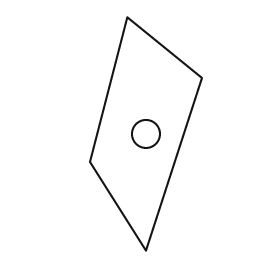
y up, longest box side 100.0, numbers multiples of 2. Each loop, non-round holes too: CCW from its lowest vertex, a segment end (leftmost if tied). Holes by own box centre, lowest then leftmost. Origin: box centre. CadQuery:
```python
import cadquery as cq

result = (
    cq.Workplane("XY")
    .moveTo(0.0, -50.0)
    .lineTo(24.0, 24.0)
    .lineTo(-8.0, 50.0)
    .lineTo(-24.0, -12.0)
    .close()
    .moveTo(0.0, 0.0)
    .circle(6.0)
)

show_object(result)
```